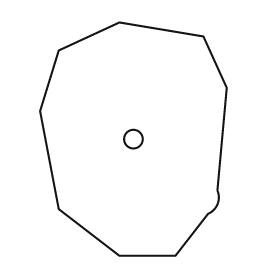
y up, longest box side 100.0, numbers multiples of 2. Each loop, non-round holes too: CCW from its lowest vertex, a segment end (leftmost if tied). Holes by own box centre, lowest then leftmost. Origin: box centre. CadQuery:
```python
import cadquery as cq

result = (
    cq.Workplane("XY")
    .moveTo(-6.0, -50.0)
    .lineTo(18.0, -50.0)
    .lineTo(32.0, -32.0)
    .threePointArc((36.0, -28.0), (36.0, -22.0))
    .lineTo(40.0, 22.0)
    .lineTo(30.0, 44.0)
    .lineTo(-6.0, 50.0)
    .lineTo(-32.0, 38.0)
    .lineTo(-40.0, 12.0)
    .lineTo(-32.0, -30.0)
    .close()
    .moveTo(0.0, 0.0)
    .circle(4.0)
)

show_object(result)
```